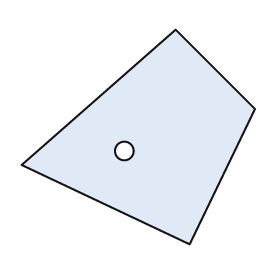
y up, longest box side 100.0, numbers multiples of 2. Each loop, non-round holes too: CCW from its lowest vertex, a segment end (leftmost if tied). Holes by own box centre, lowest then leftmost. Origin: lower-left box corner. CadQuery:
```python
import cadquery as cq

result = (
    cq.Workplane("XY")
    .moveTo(72.0, 0.0)
    .lineTo(100.0, 58.0)
    .lineTo(66.0, 92.0)
    .lineTo(0.0, 34.0)
    .close()
    .moveTo(44.0, 40.0)
    .circle(4.0)
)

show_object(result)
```